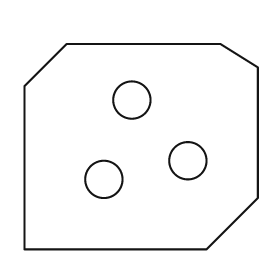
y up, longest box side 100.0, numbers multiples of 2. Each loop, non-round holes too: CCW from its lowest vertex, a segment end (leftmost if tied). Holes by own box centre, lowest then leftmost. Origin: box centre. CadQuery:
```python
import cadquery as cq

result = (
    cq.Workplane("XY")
    .moveTo(-50.0, -44.0)
    .lineTo(28.0, -44.0)
    .lineTo(50.0, -22.0)
    .lineTo(50.0, 34.0)
    .lineTo(34.0, 44.0)
    .lineTo(-32.0, 44.0)
    .lineTo(-50.0, 26.0)
    .close()
    .moveTo(-16.0, -14.0)
    .circle(8.0)
    .moveTo(20.0, -6.0)
    .circle(8.0)
    .moveTo(-4.0, 20.0)
    .circle(8.0)
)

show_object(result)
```